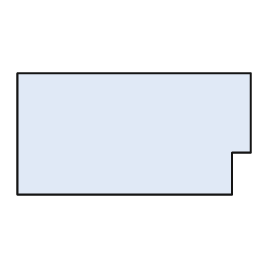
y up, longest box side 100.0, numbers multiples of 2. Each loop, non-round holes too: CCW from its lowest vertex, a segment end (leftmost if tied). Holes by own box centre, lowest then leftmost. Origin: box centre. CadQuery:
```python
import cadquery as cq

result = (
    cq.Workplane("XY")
    .moveTo(-50.0, -26.0)
    .lineTo(42.0, -26.0)
    .lineTo(42.0, -8.0)
    .lineTo(50.0, -8.0)
    .lineTo(50.0, 26.0)
    .lineTo(-50.0, 26.0)
    .close()
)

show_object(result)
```